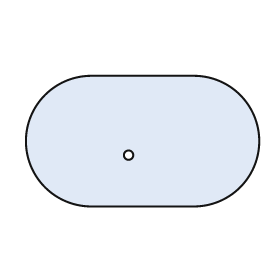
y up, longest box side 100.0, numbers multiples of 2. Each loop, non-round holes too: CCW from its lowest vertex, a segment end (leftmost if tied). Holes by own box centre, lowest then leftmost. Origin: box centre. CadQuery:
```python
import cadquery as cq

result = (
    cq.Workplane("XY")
    .moveTo(-22.0, -28.0)
    .lineTo(22.0, -28.0)
    .threePointArc((50.0, 0.0), (22.0, 28.0))
    .lineTo(-22.0, 28.0)
    .threePointArc((-50.0, 0.0), (-22.0, -28.0))
    .close()
    .moveTo(-6.0, -6.0)
    .circle(2.0)
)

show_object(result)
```